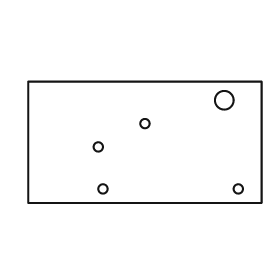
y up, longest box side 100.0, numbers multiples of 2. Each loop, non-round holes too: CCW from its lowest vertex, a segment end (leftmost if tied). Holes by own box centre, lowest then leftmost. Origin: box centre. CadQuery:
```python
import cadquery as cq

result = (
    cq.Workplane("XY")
    .moveTo(-50.0, -26.0)
    .lineTo(50.0, -26.0)
    .lineTo(50.0, 26.0)
    .lineTo(-50.0, 26.0)
    .close()
    .moveTo(-18.0, -20.0)
    .circle(2.0)
    .moveTo(40.0, -20.0)
    .circle(2.0)
    .moveTo(-20.0, -2.0)
    .circle(2.0)
    .moveTo(0.0, 8.0)
    .circle(2.0)
    .moveTo(34.0, 18.0)
    .circle(4.0)
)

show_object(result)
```